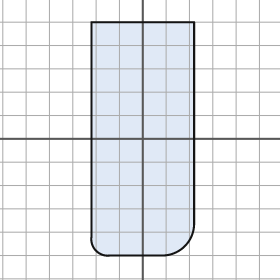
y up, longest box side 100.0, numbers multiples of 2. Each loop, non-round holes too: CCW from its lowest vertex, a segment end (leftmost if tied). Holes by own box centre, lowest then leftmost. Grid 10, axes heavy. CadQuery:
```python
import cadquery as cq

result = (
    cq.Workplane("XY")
    .moveTo(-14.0, -50.0)
    .lineTo(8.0, -50.0)
    .threePointArc((18.0, -46.0), (22.0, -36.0))
    .lineTo(22.0, 50.0)
    .lineTo(-22.0, 50.0)
    .lineTo(-22.0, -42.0)
    .threePointArc((-20.0, -48.0), (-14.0, -50.0))
    .close()
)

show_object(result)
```